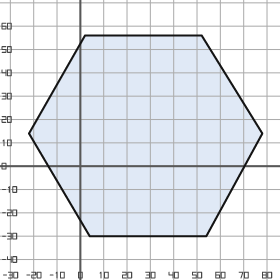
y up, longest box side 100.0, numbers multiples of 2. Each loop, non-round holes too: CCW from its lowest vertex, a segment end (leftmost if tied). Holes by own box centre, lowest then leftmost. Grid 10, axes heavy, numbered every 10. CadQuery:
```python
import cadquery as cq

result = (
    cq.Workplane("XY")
    .moveTo(4.0, -30.0)
    .lineTo(54.0, -30.0)
    .lineTo(78.0, 14.0)
    .lineTo(52.0, 56.0)
    .lineTo(2.0, 56.0)
    .lineTo(-22.0, 14.0)
    .close()
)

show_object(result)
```